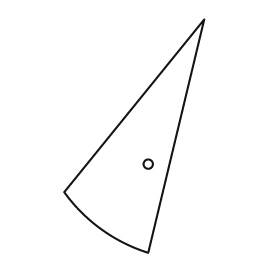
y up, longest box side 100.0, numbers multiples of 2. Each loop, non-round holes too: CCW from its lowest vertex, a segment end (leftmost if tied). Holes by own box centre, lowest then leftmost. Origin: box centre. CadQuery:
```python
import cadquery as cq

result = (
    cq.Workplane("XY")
    .moveTo(6.0, -50.0)
    .lineTo(30.0, 50.0)
    .lineTo(-30.0, -24.0)
    .threePointArc((-14.0, -40.0), (6.0, -50.0))
    .close()
    .moveTo(6.0, -12.0)
    .circle(2.0)
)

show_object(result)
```